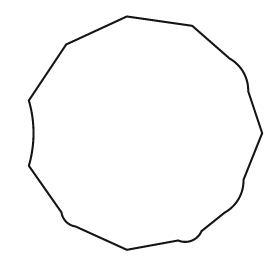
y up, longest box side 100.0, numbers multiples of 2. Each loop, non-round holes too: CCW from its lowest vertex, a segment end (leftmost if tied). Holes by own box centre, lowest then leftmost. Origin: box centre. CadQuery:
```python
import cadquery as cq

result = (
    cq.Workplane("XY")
    .moveTo(-8.0, -50.0)
    .lineTo(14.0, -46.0)
    .threePointArc((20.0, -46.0), (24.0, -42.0))
    .lineTo(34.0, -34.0)
    .threePointArc((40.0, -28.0), (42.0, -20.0))
    .lineTo(50.0, 0.0)
    .lineTo(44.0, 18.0)
    .threePointArc((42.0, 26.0), (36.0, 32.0))
    .lineTo(20.0, 46.0)
    .lineTo(-8.0, 50.0)
    .lineTo(-34.0, 38.0)
    .lineTo(-50.0, 14.0)
    .threePointArc((-48.0, 0.0), (-50.0, -14.0))
    .lineTo(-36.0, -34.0)
    .threePointArc((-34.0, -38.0), (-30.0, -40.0))
    .close()
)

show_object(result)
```